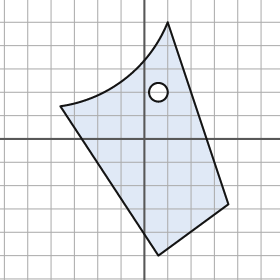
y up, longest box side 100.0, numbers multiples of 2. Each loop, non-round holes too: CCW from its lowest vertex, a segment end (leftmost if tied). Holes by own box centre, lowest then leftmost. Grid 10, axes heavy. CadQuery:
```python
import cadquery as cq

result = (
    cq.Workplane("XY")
    .moveTo(6.0, -50.0)
    .lineTo(36.0, -28.0)
    .lineTo(10.0, 50.0)
    .threePointArc((-8.0, 26.0), (-36.0, 14.0))
    .close()
    .moveTo(6.0, 20.0)
    .circle(4.0)
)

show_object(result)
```